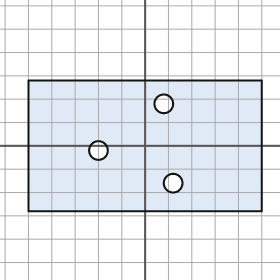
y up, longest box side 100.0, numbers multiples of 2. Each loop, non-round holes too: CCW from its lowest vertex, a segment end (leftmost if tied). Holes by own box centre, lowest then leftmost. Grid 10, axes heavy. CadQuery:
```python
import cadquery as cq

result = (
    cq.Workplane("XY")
    .moveTo(-50.0, -28.0)
    .lineTo(50.0, -28.0)
    .lineTo(50.0, 28.0)
    .lineTo(-50.0, 28.0)
    .close()
    .moveTo(12.0, -16.0)
    .circle(4.0)
    .moveTo(-20.0, -2.0)
    .circle(4.0)
    .moveTo(8.0, 18.0)
    .circle(4.0)
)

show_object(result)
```